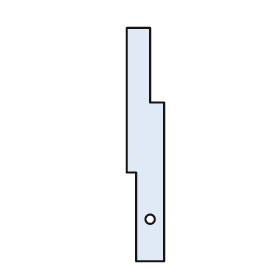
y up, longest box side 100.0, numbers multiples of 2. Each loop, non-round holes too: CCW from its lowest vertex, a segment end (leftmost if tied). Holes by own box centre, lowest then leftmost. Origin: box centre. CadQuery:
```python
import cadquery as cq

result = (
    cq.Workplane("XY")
    .moveTo(-4.0, -50.0)
    .lineTo(8.0, -50.0)
    .lineTo(8.0, 18.0)
    .lineTo(2.0, 18.0)
    .lineTo(2.0, 50.0)
    .lineTo(-8.0, 50.0)
    .lineTo(-8.0, -12.0)
    .lineTo(-4.0, -12.0)
    .close()
    .moveTo(2.0, -32.0)
    .circle(2.0)
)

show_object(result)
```